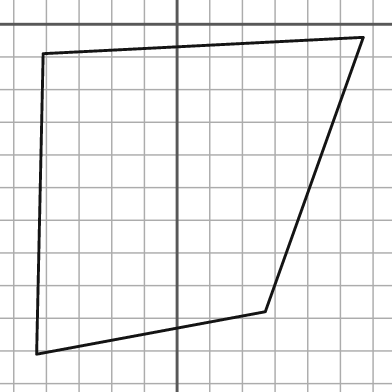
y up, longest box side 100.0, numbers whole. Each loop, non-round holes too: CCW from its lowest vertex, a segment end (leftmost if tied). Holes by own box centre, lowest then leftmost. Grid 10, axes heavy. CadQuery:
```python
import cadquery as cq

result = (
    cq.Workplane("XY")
    .moveTo(-43.0, -101.0)
    .lineTo(27.0, -88.0)
    .lineTo(57.0, -4.0)
    .lineTo(-41.0, -9.0)
    .close()
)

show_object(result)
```